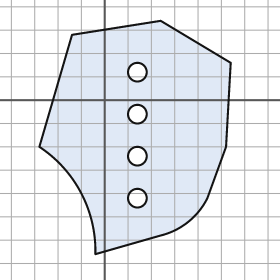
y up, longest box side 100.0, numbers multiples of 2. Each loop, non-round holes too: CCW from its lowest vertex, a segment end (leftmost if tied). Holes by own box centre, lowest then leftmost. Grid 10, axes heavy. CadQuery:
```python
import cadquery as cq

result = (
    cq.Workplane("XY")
    .moveTo(-4.0, -66.0)
    .lineTo(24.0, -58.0)
    .threePointArc((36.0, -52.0), (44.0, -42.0))
    .lineTo(52.0, -20.0)
    .lineTo(54.0, 16.0)
    .lineTo(24.0, 34.0)
    .lineTo(-14.0, 28.0)
    .lineTo(-28.0, -20.0)
    .threePointArc((-10.0, -40.0), (-4.0, -66.0))
    .close()
    .moveTo(14.0, -42.0)
    .circle(4.0)
    .moveTo(14.0, -24.0)
    .circle(4.0)
    .moveTo(14.0, -6.0)
    .circle(4.0)
    .moveTo(14.0, 12.0)
    .circle(4.0)
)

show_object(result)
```